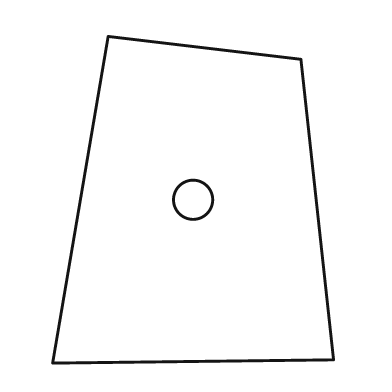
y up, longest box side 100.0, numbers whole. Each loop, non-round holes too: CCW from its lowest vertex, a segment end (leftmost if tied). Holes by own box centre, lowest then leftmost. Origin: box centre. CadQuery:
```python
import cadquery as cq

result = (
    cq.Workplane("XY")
    .moveTo(-43.0, -50.0)
    .lineTo(43.0, -49.0)
    .lineTo(33.0, 43.0)
    .lineTo(-26.0, 50.0)
    .close()
    .moveTo(0.0, 0.0)
    .circle(6.0)
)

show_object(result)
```